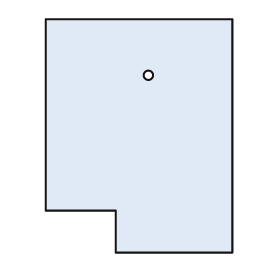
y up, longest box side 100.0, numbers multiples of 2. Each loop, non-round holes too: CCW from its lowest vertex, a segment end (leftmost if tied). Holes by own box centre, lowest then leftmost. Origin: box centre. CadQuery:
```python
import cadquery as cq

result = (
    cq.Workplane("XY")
    .moveTo(-10.0, -50.0)
    .lineTo(40.0, -50.0)
    .lineTo(40.0, 50.0)
    .lineTo(-40.0, 50.0)
    .lineTo(-40.0, -32.0)
    .lineTo(-10.0, -32.0)
    .close()
    .moveTo(4.0, 26.0)
    .circle(2.0)
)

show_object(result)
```